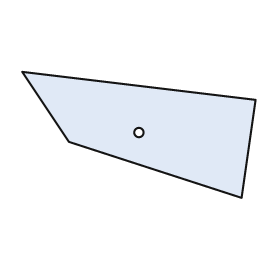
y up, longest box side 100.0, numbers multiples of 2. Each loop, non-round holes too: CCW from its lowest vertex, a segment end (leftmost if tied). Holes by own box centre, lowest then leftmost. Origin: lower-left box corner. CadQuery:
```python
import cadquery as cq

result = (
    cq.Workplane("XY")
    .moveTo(94.0, 0.0)
    .lineTo(100.0, 42.0)
    .lineTo(0.0, 54.0)
    .lineTo(20.0, 24.0)
    .close()
    .moveTo(50.0, 28.0)
    .circle(2.0)
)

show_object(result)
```